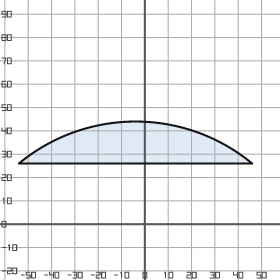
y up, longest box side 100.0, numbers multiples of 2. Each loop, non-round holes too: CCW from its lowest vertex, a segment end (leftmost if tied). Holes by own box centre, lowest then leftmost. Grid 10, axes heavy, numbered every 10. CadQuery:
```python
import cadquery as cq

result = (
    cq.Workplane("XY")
    .moveTo(-54.0, 26.0)
    .lineTo(46.0, 26.0)
    .threePointArc((-4.0, 44.0), (-54.0, 26.0))
    .close()
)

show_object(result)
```